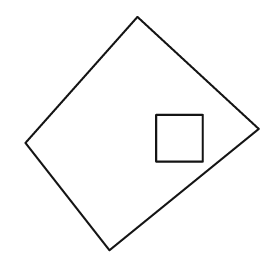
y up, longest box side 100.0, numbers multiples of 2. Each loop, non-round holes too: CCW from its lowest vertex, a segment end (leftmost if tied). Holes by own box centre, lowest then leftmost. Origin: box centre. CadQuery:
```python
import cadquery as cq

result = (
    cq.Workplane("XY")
    .moveTo(-14.0, -50.0)
    .lineTo(50.0, 2.0)
    .lineTo(-2.0, 50.0)
    .lineTo(-50.0, -4.0)
    .close()
    .moveTo(6.0, -12.0)
    .lineTo(26.0, -12.0)
    .lineTo(26.0, 8.0)
    .lineTo(6.0, 8.0)
    .close()
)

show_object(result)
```